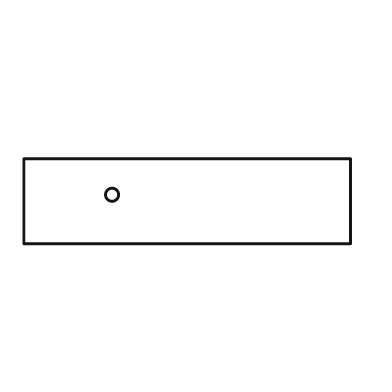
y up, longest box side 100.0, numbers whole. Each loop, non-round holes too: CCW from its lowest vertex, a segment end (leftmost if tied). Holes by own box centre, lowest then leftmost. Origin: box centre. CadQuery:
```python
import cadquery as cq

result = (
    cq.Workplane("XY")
    .moveTo(-50.0, -13.0)
    .lineTo(50.0, -13.0)
    .lineTo(50.0, 13.0)
    .lineTo(-50.0, 13.0)
    .close()
    .moveTo(-23.0, 2.0)
    .circle(2.0)
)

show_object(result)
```